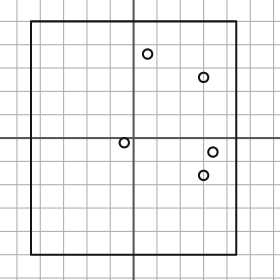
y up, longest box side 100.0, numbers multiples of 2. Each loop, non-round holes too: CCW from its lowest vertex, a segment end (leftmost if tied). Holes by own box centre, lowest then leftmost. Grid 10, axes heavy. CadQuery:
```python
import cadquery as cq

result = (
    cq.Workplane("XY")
    .moveTo(-44.0, -50.0)
    .lineTo(44.0, -50.0)
    .lineTo(44.0, 50.0)
    .lineTo(-44.0, 50.0)
    .close()
    .moveTo(30.0, -16.0)
    .circle(2.0)
    .moveTo(34.0, -6.0)
    .circle(2.0)
    .moveTo(-4.0, -2.0)
    .circle(2.0)
    .moveTo(30.0, 26.0)
    .circle(2.0)
    .moveTo(6.0, 36.0)
    .circle(2.0)
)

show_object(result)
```